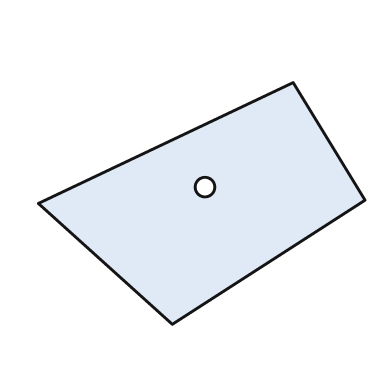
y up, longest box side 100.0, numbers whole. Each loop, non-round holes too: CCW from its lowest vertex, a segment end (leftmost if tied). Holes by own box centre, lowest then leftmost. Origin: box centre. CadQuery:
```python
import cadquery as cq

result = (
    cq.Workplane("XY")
    .moveTo(-9.0, -37.0)
    .lineTo(50.0, 1.0)
    .lineTo(28.0, 37.0)
    .lineTo(-50.0, 0.0)
    .close()
    .moveTo(1.0, 5.0)
    .circle(3.0)
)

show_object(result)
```